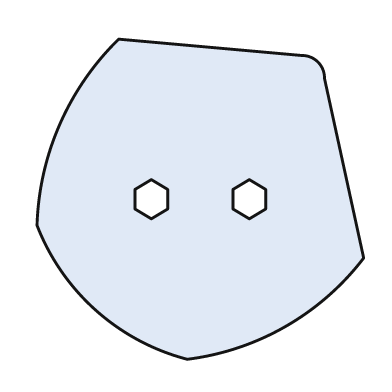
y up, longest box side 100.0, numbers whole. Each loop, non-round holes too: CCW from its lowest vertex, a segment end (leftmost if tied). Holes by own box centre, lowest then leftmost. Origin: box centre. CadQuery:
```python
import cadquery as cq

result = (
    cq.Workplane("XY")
    .moveTo(-4.0, -49.0)
    .threePointArc((26.0, -39.0), (50.0, -18.0))
    .lineTo(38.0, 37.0)
    .threePointArc((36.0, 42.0), (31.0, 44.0))
    .lineTo(-25.0, 49.0)
    .threePointArc((-43.0, 23.0), (-50.0, -8.0))
    .threePointArc((-32.0, -34.0), (-4.0, -49.0))
    .close()
    .moveTo(-15.0, -6.0)
    .lineTo(-10.0, -3.0)
    .lineTo(-10.0, 3.0)
    .lineTo(-15.0, 6.0)
    .lineTo(-20.0, 3.0)
    .lineTo(-20.0, -3.0)
    .close()
    .moveTo(15.0, -6.0)
    .lineTo(20.0, -3.0)
    .lineTo(20.0, 3.0)
    .lineTo(15.0, 6.0)
    .lineTo(10.0, 3.0)
    .lineTo(10.0, -3.0)
    .close()
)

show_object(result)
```